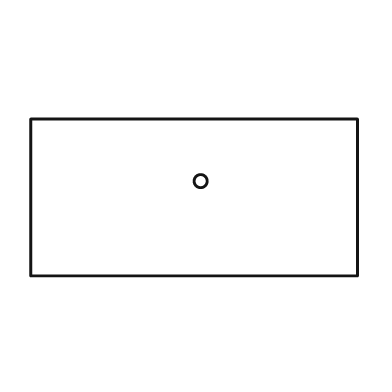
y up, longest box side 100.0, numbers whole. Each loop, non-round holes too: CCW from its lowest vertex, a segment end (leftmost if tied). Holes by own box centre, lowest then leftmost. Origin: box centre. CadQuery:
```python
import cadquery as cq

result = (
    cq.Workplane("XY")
    .moveTo(-50.0, -24.0)
    .lineTo(50.0, -24.0)
    .lineTo(50.0, 24.0)
    .lineTo(-50.0, 24.0)
    .close()
    .moveTo(2.0, 5.0)
    .circle(2.0)
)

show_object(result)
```